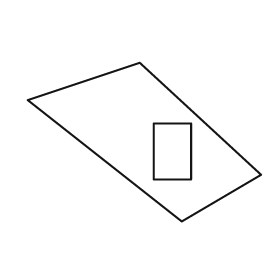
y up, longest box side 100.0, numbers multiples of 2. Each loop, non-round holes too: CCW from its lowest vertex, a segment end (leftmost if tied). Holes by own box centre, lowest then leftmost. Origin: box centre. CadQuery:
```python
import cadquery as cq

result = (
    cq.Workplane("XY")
    .moveTo(16.0, -34.0)
    .lineTo(50.0, -14.0)
    .lineTo(-2.0, 34.0)
    .lineTo(-50.0, 18.0)
    .close()
    .moveTo(4.0, -16.0)
    .lineTo(20.0, -16.0)
    .lineTo(20.0, 8.0)
    .lineTo(4.0, 8.0)
    .close()
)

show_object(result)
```